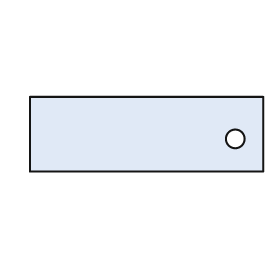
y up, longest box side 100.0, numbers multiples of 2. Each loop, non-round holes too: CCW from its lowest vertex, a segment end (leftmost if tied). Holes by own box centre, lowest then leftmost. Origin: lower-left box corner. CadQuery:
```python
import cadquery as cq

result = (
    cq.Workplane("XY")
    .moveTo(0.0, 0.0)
    .lineTo(100.0, 0.0)
    .lineTo(100.0, 32.0)
    .lineTo(0.0, 32.0)
    .close()
    .moveTo(88.0, 14.0)
    .circle(4.0)
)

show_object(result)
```